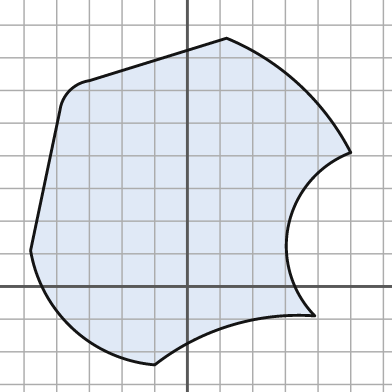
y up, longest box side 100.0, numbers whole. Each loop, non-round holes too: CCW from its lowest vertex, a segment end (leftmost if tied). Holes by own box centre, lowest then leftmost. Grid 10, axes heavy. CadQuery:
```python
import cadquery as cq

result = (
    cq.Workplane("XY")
    .moveTo(-10.0, -24.0)
    .threePointArc((13.0, -12.0), (39.0, -9.0))
    .threePointArc((31.0, 19.0), (50.0, 41.0))
    .threePointArc((34.0, 62.0), (12.0, 76.0))
    .lineTo(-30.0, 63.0)
    .threePointArc((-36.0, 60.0), (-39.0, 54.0))
    .lineTo(-48.0, 11.0)
    .threePointArc((-35.0, -13.0), (-10.0, -24.0))
    .close()
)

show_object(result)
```